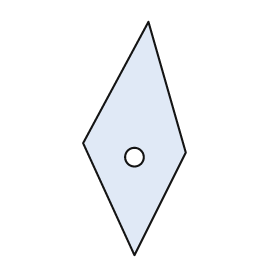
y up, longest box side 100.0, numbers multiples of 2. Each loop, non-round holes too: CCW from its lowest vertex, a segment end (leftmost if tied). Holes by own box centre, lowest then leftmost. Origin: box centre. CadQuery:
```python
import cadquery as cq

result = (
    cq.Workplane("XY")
    .moveTo(0.0, -50.0)
    .lineTo(22.0, -6.0)
    .lineTo(6.0, 50.0)
    .lineTo(-22.0, -2.0)
    .close()
    .moveTo(0.0, -8.0)
    .circle(4.0)
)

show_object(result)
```